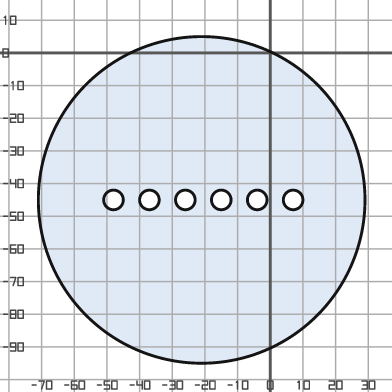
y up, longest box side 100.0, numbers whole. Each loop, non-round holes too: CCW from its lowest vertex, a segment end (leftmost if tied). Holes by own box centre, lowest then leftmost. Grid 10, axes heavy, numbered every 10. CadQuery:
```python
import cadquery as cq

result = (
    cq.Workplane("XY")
    .moveTo(-21.0, -45.0)
    .circle(50.0)
    .moveTo(-48.0, -45.0)
    .circle(3.0)
    .moveTo(-37.0, -45.0)
    .circle(3.0)
    .moveTo(-26.0, -45.0)
    .circle(3.0)
    .moveTo(-15.0, -45.0)
    .circle(3.0)
    .moveTo(-4.0, -45.0)
    .circle(3.0)
    .moveTo(7.0, -45.0)
    .circle(3.0)
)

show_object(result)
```